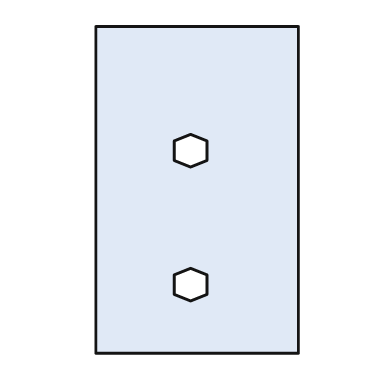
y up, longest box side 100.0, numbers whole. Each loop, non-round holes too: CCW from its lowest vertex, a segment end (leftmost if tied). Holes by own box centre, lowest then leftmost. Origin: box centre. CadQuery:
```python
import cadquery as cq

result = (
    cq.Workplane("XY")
    .moveTo(-31.0, -50.0)
    .lineTo(31.0, -50.0)
    .lineTo(31.0, 50.0)
    .lineTo(-31.0, 50.0)
    .close()
    .moveTo(-2.0, -34.0)
    .lineTo(3.0, -32.0)
    .lineTo(3.0, -26.0)
    .lineTo(-2.0, -24.0)
    .lineTo(-7.0, -26.0)
    .lineTo(-7.0, -32.0)
    .close()
    .moveTo(-2.0, 7.0)
    .lineTo(3.0, 9.0)
    .lineTo(3.0, 15.0)
    .lineTo(-2.0, 17.0)
    .lineTo(-7.0, 15.0)
    .lineTo(-7.0, 9.0)
    .close()
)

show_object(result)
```